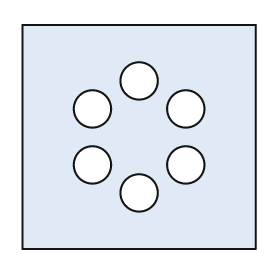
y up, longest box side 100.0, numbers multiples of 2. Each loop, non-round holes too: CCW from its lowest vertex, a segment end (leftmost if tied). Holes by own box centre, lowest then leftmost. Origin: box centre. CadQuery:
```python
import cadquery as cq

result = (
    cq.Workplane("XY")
    .moveTo(-50.0, -48.0)
    .lineTo(50.0, -48.0)
    .lineTo(50.0, 48.0)
    .lineTo(-50.0, 48.0)
    .close()
    .moveTo(0.0, -24.0)
    .circle(8.0)
    .moveTo(-20.0, -12.0)
    .circle(8.0)
    .moveTo(20.0, -12.0)
    .circle(8.0)
    .moveTo(-20.0, 12.0)
    .circle(8.0)
    .moveTo(20.0, 12.0)
    .circle(8.0)
    .moveTo(0.0, 24.0)
    .circle(8.0)
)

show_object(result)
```